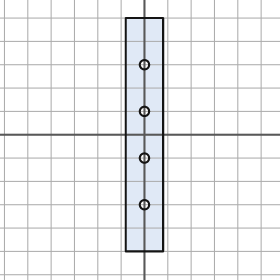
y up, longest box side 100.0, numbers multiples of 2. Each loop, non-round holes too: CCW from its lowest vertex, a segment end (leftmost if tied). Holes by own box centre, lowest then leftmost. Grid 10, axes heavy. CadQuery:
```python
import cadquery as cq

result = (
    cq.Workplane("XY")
    .moveTo(-8.0, -50.0)
    .lineTo(8.0, -50.0)
    .lineTo(8.0, 50.0)
    .lineTo(-8.0, 50.0)
    .close()
    .moveTo(0.0, -30.0)
    .circle(2.0)
    .moveTo(0.0, -10.0)
    .circle(2.0)
    .moveTo(0.0, 10.0)
    .circle(2.0)
    .moveTo(0.0, 30.0)
    .circle(2.0)
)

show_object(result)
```